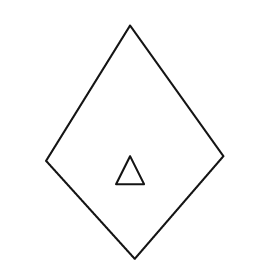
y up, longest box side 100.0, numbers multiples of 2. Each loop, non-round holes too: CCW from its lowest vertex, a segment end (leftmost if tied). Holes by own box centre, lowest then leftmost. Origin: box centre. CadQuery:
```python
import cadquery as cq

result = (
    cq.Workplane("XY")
    .moveTo(0.0, -50.0)
    .lineTo(38.0, -6.0)
    .lineTo(-2.0, 50.0)
    .lineTo(-38.0, -8.0)
    .close()
    .moveTo(-8.0, -18.0)
    .lineTo(4.0, -18.0)
    .lineTo(-2.0, -6.0)
    .close()
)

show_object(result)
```